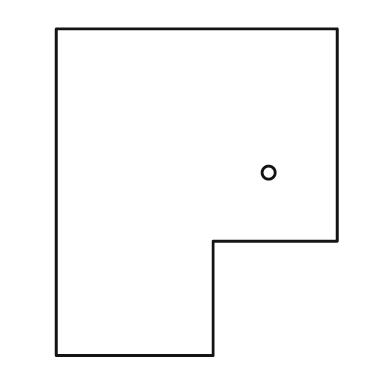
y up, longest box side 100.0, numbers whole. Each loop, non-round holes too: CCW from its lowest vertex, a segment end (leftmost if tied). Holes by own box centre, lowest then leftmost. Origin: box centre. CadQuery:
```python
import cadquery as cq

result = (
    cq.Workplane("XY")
    .moveTo(-43.0, -50.0)
    .lineTo(5.0, -50.0)
    .lineTo(5.0, -15.0)
    .lineTo(43.0, -15.0)
    .lineTo(43.0, 50.0)
    .lineTo(-43.0, 50.0)
    .close()
    .moveTo(22.0, 6.0)
    .circle(2.0)
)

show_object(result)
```